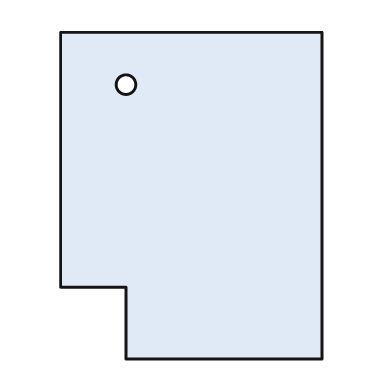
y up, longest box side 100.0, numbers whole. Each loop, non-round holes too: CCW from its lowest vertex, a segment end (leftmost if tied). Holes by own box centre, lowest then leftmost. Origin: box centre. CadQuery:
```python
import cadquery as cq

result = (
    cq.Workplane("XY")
    .moveTo(-20.0, -50.0)
    .lineTo(40.0, -50.0)
    .lineTo(40.0, 50.0)
    .lineTo(-40.0, 50.0)
    .lineTo(-40.0, -28.0)
    .lineTo(-20.0, -28.0)
    .close()
    .moveTo(-20.0, 34.0)
    .circle(3.0)
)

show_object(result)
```